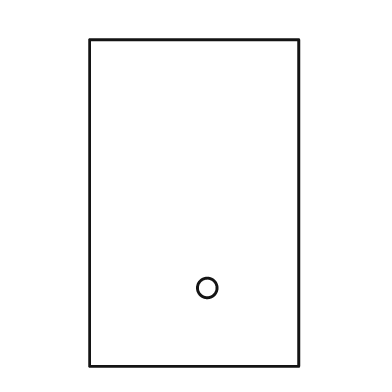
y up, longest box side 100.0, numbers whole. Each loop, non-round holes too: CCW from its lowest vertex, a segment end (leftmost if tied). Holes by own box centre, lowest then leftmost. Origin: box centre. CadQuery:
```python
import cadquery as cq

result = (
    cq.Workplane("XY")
    .moveTo(-32.0, -50.0)
    .lineTo(32.0, -50.0)
    .lineTo(32.0, 50.0)
    .lineTo(-32.0, 50.0)
    .close()
    .moveTo(4.0, -26.0)
    .circle(3.0)
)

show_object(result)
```